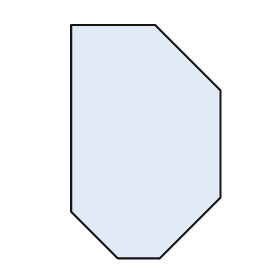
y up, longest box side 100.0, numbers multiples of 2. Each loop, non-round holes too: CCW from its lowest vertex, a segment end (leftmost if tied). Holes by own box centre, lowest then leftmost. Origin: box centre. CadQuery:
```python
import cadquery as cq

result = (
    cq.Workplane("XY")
    .moveTo(-12.0, -50.0)
    .lineTo(6.0, -50.0)
    .lineTo(32.0, -24.0)
    .lineTo(32.0, 22.0)
    .lineTo(4.0, 50.0)
    .lineTo(-32.0, 50.0)
    .lineTo(-32.0, -30.0)
    .close()
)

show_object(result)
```